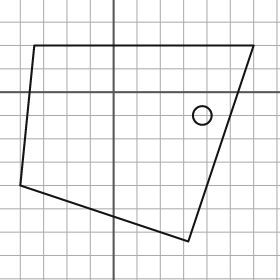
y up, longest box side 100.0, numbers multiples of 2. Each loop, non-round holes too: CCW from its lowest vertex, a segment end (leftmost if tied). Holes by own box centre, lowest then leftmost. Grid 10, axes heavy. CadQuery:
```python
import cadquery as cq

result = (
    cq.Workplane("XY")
    .moveTo(32.0, -64.0)
    .lineTo(60.0, 20.0)
    .lineTo(-34.0, 20.0)
    .lineTo(-40.0, -40.0)
    .close()
    .moveTo(38.0, -10.0)
    .circle(4.0)
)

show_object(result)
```